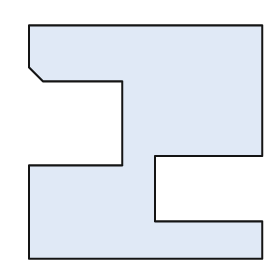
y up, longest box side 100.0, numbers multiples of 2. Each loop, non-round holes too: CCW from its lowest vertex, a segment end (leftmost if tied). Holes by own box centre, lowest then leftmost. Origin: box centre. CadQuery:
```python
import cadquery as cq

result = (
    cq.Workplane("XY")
    .moveTo(-50.0, -50.0)
    .lineTo(50.0, -50.0)
    .lineTo(50.0, -34.0)
    .lineTo(4.0, -34.0)
    .lineTo(4.0, -6.0)
    .lineTo(50.0, -6.0)
    .lineTo(50.0, 50.0)
    .lineTo(-50.0, 50.0)
    .lineTo(-50.0, 32.0)
    .lineTo(-44.0, 26.0)
    .lineTo(-10.0, 26.0)
    .lineTo(-10.0, -10.0)
    .lineTo(-50.0, -10.0)
    .close()
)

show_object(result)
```